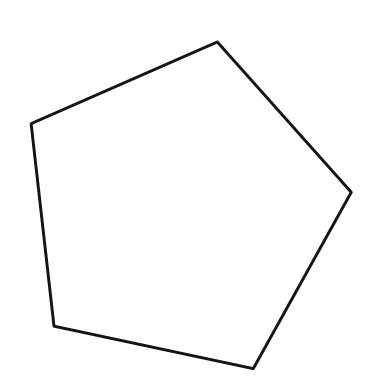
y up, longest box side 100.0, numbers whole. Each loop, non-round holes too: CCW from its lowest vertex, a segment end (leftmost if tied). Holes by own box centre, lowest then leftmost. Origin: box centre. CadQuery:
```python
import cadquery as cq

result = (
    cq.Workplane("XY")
    .moveTo(19.0, -50.0)
    .lineTo(49.0, 4.0)
    .lineTo(8.0, 50.0)
    .lineTo(-49.0, 25.0)
    .lineTo(-42.0, -37.0)
    .close()
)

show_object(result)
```